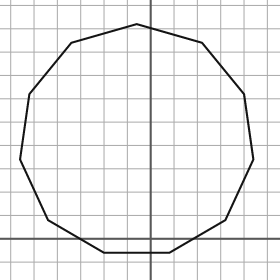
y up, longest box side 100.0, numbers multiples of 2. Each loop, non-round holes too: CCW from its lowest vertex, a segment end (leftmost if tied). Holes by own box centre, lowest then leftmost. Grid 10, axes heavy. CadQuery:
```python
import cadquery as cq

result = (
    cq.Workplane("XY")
    .moveTo(-20.0, -6.0)
    .lineTo(8.0, -6.0)
    .lineTo(32.0, 8.0)
    .lineTo(44.0, 34.0)
    .lineTo(40.0, 62.0)
    .lineTo(22.0, 84.0)
    .lineTo(-6.0, 92.0)
    .lineTo(-34.0, 84.0)
    .lineTo(-52.0, 62.0)
    .lineTo(-56.0, 34.0)
    .lineTo(-44.0, 8.0)
    .close()
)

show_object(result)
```